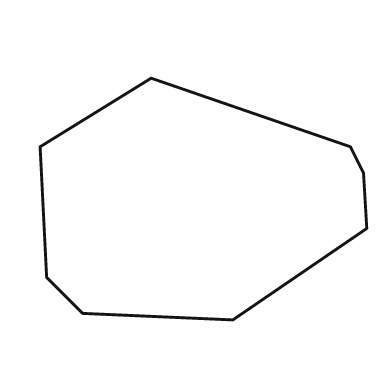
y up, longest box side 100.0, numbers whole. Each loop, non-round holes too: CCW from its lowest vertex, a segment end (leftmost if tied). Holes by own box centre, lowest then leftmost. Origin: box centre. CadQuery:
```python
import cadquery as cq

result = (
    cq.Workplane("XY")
    .moveTo(9.0, -37.0)
    .lineTo(50.0, -9.0)
    .lineTo(49.0, 8.0)
    .lineTo(45.0, 16.0)
    .lineTo(-16.0, 37.0)
    .lineTo(-50.0, 16.0)
    .lineTo(-48.0, -24.0)
    .lineTo(-37.0, -35.0)
    .close()
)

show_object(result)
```